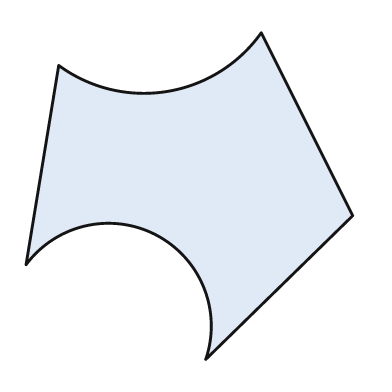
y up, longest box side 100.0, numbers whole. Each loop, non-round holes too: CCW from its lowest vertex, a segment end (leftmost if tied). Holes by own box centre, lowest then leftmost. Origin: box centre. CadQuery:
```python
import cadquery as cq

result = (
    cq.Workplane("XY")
    .moveTo(5.0, -50.0)
    .lineTo(50.0, -6.0)
    .lineTo(22.0, 50.0)
    .threePointArc((-7.0, 32.0), (-40.0, 40.0))
    .lineTo(-50.0, -21.0)
    .threePointArc((-10.0, -12.0), (5.0, -50.0))
    .close()
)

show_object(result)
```